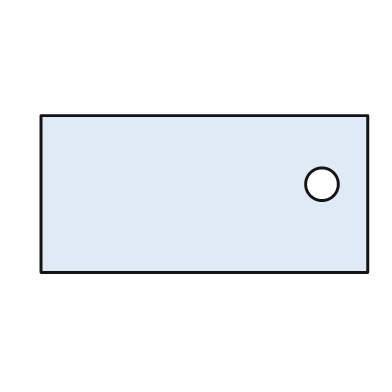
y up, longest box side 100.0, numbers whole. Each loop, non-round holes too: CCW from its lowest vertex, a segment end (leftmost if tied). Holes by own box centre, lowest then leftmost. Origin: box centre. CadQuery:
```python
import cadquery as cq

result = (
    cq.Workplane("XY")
    .moveTo(-50.0, -24.0)
    .lineTo(50.0, -24.0)
    .lineTo(50.0, 24.0)
    .lineTo(-50.0, 24.0)
    .close()
    .moveTo(36.0, 3.0)
    .circle(5.0)
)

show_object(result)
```